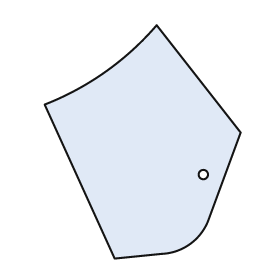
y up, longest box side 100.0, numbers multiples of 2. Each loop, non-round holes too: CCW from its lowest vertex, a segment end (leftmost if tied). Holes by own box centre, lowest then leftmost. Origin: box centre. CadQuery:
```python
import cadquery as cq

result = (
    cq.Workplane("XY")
    .moveTo(-12.0, -50.0)
    .lineTo(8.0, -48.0)
    .threePointArc((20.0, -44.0), (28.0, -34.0))
    .lineTo(42.0, 4.0)
    .lineTo(6.0, 50.0)
    .threePointArc((-16.0, 30.0), (-42.0, 16.0))
    .close()
    .moveTo(26.0, -14.0)
    .circle(2.0)
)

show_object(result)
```